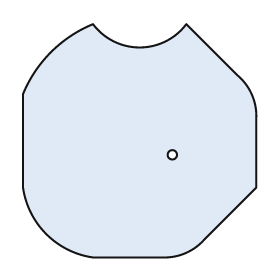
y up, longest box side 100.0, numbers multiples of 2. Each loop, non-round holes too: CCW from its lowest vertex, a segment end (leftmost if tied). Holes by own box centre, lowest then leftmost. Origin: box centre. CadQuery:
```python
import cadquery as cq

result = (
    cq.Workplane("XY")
    .moveTo(-20.0, -50.0)
    .lineTo(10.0, -50.0)
    .threePointArc((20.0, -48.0), (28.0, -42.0))
    .lineTo(50.0, -20.0)
    .lineTo(50.0, 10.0)
    .threePointArc((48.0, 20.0), (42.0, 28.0))
    .lineTo(20.0, 50.0)
    .threePointArc((0.0, 40.0), (-20.0, 50.0))
    .threePointArc((-38.0, 38.0), (-50.0, 20.0))
    .lineTo(-50.0, -20.0)
    .threePointArc((-40.0, -40.0), (-20.0, -50.0))
    .close()
    .moveTo(14.0, -6.0)
    .circle(2.0)
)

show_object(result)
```